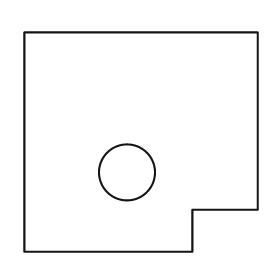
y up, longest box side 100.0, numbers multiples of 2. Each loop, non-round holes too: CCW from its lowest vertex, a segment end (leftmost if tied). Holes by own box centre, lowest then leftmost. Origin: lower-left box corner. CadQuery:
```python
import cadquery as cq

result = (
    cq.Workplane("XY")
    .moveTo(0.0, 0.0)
    .lineTo(72.0, 0.0)
    .lineTo(72.0, 18.0)
    .lineTo(100.0, 18.0)
    .lineTo(100.0, 94.0)
    .lineTo(0.0, 94.0)
    .close()
    .moveTo(44.0, 34.0)
    .circle(12.0)
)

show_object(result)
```